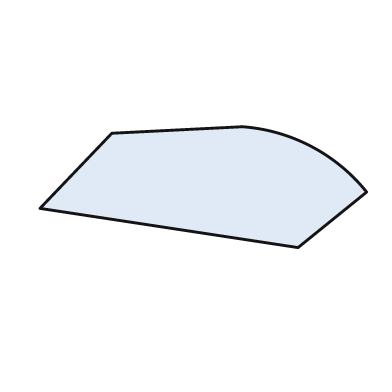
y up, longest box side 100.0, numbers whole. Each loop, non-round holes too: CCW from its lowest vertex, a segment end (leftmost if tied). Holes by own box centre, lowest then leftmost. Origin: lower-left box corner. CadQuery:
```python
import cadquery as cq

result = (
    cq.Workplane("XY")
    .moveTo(79.0, 0.0)
    .lineTo(100.0, 17.0)
    .threePointArc((83.0, 31.0), (62.0, 37.0))
    .lineTo(22.0, 35.0)
    .lineTo(0.0, 12.0)
    .close()
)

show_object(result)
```